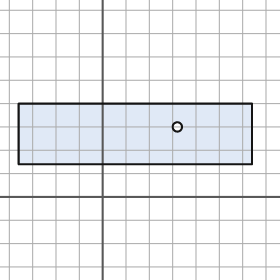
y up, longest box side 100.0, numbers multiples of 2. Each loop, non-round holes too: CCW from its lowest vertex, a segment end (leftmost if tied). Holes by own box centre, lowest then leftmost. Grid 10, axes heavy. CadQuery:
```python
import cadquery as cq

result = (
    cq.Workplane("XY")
    .moveTo(-36.0, 14.0)
    .lineTo(64.0, 14.0)
    .lineTo(64.0, 40.0)
    .lineTo(-36.0, 40.0)
    .close()
    .moveTo(32.0, 30.0)
    .circle(2.0)
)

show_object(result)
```